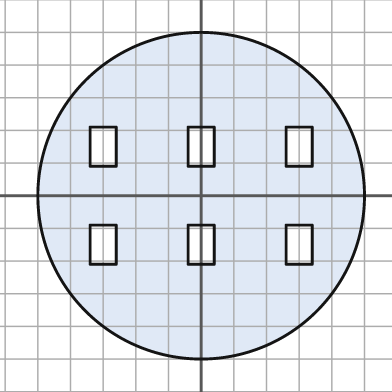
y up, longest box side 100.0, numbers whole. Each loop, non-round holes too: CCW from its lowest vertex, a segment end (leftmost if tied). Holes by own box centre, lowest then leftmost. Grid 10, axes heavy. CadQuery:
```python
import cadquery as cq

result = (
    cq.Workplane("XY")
    .moveTo(0.0, 0.0)
    .circle(50.0)
    .moveTo(-34.0, -21.0)
    .lineTo(-26.0, -21.0)
    .lineTo(-26.0, -9.0)
    .lineTo(-34.0, -9.0)
    .close()
    .moveTo(-4.0, -21.0)
    .lineTo(4.0, -21.0)
    .lineTo(4.0, -9.0)
    .lineTo(-4.0, -9.0)
    .close()
    .moveTo(26.0, -21.0)
    .lineTo(34.0, -21.0)
    .lineTo(34.0, -9.0)
    .lineTo(26.0, -9.0)
    .close()
    .moveTo(-34.0, 9.0)
    .lineTo(-26.0, 9.0)
    .lineTo(-26.0, 21.0)
    .lineTo(-34.0, 21.0)
    .close()
    .moveTo(-4.0, 9.0)
    .lineTo(4.0, 9.0)
    .lineTo(4.0, 21.0)
    .lineTo(-4.0, 21.0)
    .close()
    .moveTo(26.0, 9.0)
    .lineTo(34.0, 9.0)
    .lineTo(34.0, 21.0)
    .lineTo(26.0, 21.0)
    .close()
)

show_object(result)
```